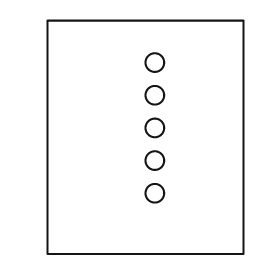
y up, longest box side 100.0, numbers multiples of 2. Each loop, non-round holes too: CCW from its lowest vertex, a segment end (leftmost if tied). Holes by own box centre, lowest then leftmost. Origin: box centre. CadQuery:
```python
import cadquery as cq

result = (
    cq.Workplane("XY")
    .moveTo(-42.0, -50.0)
    .lineTo(42.0, -50.0)
    .lineTo(42.0, 50.0)
    .lineTo(-42.0, 50.0)
    .close()
    .moveTo(4.0, -24.0)
    .circle(4.0)
    .moveTo(4.0, -10.0)
    .circle(4.0)
    .moveTo(4.0, 4.0)
    .circle(4.0)
    .moveTo(4.0, 18.0)
    .circle(4.0)
    .moveTo(4.0, 32.0)
    .circle(4.0)
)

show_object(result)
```